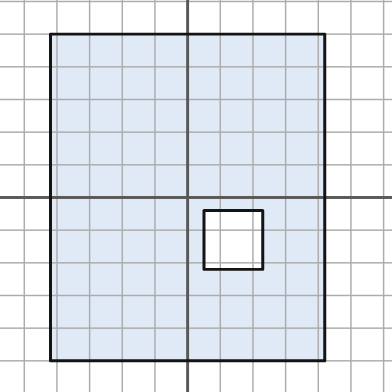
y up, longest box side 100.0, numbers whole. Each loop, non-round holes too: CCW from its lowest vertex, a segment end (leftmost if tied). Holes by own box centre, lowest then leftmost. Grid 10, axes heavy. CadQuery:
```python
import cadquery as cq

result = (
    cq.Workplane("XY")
    .moveTo(-42.0, -50.0)
    .lineTo(42.0, -50.0)
    .lineTo(42.0, 50.0)
    .lineTo(-42.0, 50.0)
    .close()
    .moveTo(5.0, -22.0)
    .lineTo(23.0, -22.0)
    .lineTo(23.0, -4.0)
    .lineTo(5.0, -4.0)
    .close()
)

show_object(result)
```